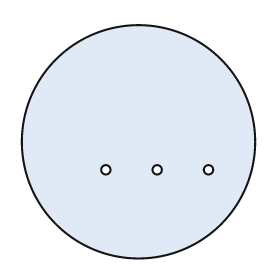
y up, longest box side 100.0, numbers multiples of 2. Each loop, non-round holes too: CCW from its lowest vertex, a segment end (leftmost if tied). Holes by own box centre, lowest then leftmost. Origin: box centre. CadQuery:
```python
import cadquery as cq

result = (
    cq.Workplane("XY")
    .moveTo(0.0, 0.0)
    .circle(50.0)
    .moveTo(-14.0, -12.0)
    .circle(2.0)
    .moveTo(8.0, -12.0)
    .circle(2.0)
    .moveTo(30.0, -12.0)
    .circle(2.0)
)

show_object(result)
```